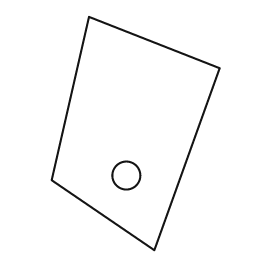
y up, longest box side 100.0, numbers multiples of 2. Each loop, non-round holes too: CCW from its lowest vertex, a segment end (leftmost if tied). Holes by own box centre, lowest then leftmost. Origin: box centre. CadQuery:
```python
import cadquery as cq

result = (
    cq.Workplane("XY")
    .moveTo(8.0, -50.0)
    .lineTo(36.0, 28.0)
    .lineTo(-20.0, 50.0)
    .lineTo(-36.0, -20.0)
    .close()
    .moveTo(-4.0, -18.0)
    .circle(6.0)
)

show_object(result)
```